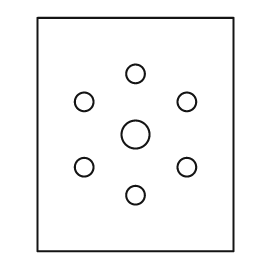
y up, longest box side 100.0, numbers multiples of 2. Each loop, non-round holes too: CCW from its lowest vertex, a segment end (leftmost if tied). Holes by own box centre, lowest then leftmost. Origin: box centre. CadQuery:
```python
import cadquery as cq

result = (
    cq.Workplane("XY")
    .moveTo(-42.0, -50.0)
    .lineTo(42.0, -50.0)
    .lineTo(42.0, 50.0)
    .lineTo(-42.0, 50.0)
    .close()
    .moveTo(0.0, -26.0)
    .circle(4.0)
    .moveTo(-22.0, -14.0)
    .circle(4.0)
    .moveTo(22.0, -14.0)
    .circle(4.0)
    .moveTo(0.0, 0.0)
    .circle(6.0)
    .moveTo(-22.0, 14.0)
    .circle(4.0)
    .moveTo(22.0, 14.0)
    .circle(4.0)
    .moveTo(0.0, 26.0)
    .circle(4.0)
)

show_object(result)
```